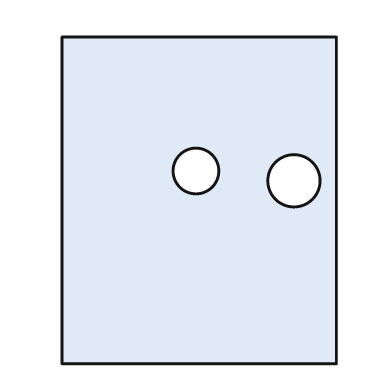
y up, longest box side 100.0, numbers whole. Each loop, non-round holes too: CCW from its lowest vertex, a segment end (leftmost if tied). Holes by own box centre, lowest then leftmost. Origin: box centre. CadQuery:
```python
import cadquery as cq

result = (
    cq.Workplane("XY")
    .moveTo(-42.0, -50.0)
    .lineTo(42.0, -50.0)
    .lineTo(42.0, 50.0)
    .lineTo(-42.0, 50.0)
    .close()
    .moveTo(29.0, 6.0)
    .circle(8.0)
    .moveTo(-1.0, 9.0)
    .circle(7.0)
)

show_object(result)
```